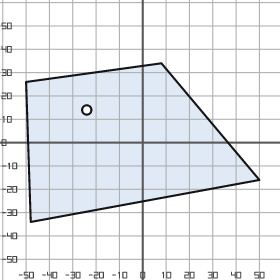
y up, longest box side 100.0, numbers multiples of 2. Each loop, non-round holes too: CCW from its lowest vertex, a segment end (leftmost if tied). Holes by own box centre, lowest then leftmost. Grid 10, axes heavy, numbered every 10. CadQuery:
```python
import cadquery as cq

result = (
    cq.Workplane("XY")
    .moveTo(-48.0, -34.0)
    .lineTo(50.0, -16.0)
    .lineTo(8.0, 34.0)
    .lineTo(-50.0, 26.0)
    .close()
    .moveTo(-24.0, 14.0)
    .circle(2.0)
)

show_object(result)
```